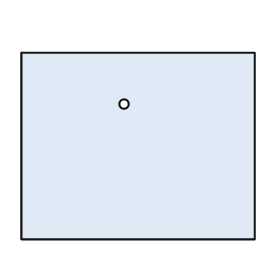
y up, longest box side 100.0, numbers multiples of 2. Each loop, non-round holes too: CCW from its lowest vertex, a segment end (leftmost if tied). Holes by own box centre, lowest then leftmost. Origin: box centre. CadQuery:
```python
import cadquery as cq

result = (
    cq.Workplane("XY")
    .moveTo(-50.0, -40.0)
    .lineTo(50.0, -40.0)
    .lineTo(50.0, 40.0)
    .lineTo(-50.0, 40.0)
    .close()
    .moveTo(-6.0, 18.0)
    .circle(2.0)
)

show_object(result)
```